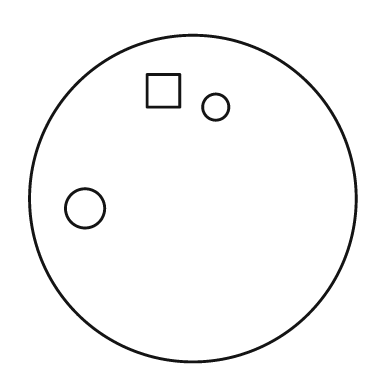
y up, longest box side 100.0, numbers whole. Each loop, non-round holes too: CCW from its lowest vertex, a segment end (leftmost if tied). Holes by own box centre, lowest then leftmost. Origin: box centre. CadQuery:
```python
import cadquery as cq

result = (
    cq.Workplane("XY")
    .moveTo(0.0, 0.0)
    .circle(50.0)
    .moveTo(-33.0, -3.0)
    .circle(6.0)
    .moveTo(7.0, 28.0)
    .circle(4.0)
    .moveTo(-14.0, 28.0)
    .lineTo(-4.0, 28.0)
    .lineTo(-4.0, 38.0)
    .lineTo(-14.0, 38.0)
    .close()
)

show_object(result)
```